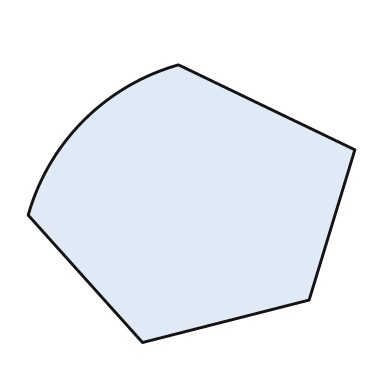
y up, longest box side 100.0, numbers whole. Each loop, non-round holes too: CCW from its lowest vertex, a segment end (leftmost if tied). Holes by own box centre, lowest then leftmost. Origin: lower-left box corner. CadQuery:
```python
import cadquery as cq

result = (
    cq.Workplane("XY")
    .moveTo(35.0, 0.0)
    .lineTo(86.0, 13.0)
    .lineTo(100.0, 59.0)
    .lineTo(46.0, 85.0)
    .threePointArc((17.0, 68.0), (0.0, 39.0))
    .close()
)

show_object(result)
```